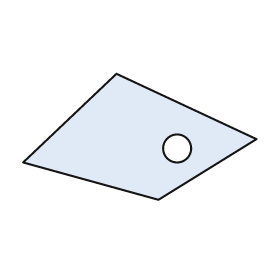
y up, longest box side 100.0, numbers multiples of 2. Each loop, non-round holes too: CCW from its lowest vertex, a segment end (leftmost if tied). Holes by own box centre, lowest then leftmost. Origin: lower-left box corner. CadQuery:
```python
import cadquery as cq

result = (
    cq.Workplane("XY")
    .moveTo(58.0, 0.0)
    .lineTo(100.0, 26.0)
    .lineTo(40.0, 54.0)
    .lineTo(0.0, 16.0)
    .close()
    .moveTo(66.0, 22.0)
    .circle(6.0)
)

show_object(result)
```